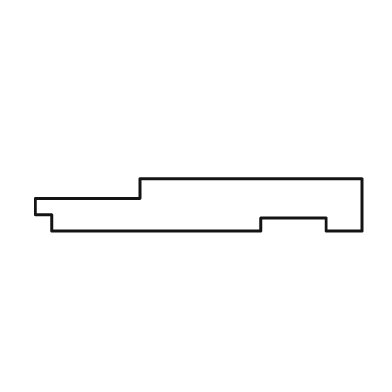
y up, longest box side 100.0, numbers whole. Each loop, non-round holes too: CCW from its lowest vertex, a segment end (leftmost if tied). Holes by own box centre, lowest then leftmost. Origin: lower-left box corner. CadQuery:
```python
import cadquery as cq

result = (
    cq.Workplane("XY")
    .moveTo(5.0, 0.0)
    .lineTo(69.0, 0.0)
    .lineTo(69.0, 4.0)
    .lineTo(89.0, 4.0)
    .lineTo(89.0, 0.0)
    .lineTo(100.0, 0.0)
    .lineTo(100.0, 16.0)
    .lineTo(32.0, 16.0)
    .lineTo(32.0, 10.0)
    .lineTo(0.0, 10.0)
    .lineTo(0.0, 5.0)
    .lineTo(5.0, 5.0)
    .close()
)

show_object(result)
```